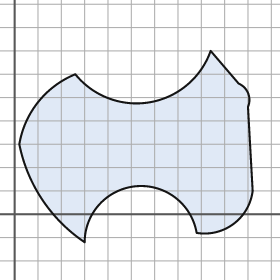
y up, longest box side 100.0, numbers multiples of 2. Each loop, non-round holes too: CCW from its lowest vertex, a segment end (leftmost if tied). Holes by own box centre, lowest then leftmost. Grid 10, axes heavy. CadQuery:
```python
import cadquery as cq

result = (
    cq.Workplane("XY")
    .moveTo(30.0, -12.0)
    .threePointArc((52.0, 12.0), (78.0, -8.0))
    .threePointArc((94.0, -4.0), (102.0, 10.0))
    .lineTo(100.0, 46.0)
    .threePointArc((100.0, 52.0), (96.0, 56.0))
    .lineTo(84.0, 70.0)
    .threePointArc((58.0, 48.0), (26.0, 60.0))
    .threePointArc((10.0, 48.0), (2.0, 30.0))
    .threePointArc((12.0, 6.0), (30.0, -12.0))
    .close()
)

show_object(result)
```